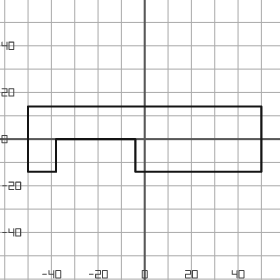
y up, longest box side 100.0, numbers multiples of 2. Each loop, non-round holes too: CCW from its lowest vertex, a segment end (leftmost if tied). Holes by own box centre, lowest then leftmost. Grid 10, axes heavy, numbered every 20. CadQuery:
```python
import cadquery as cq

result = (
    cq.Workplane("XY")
    .moveTo(-50.0, -14.0)
    .lineTo(-38.0, -14.0)
    .lineTo(-38.0, 0.0)
    .lineTo(-4.0, 0.0)
    .lineTo(-4.0, -14.0)
    .lineTo(50.0, -14.0)
    .lineTo(50.0, 14.0)
    .lineTo(-50.0, 14.0)
    .close()
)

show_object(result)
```